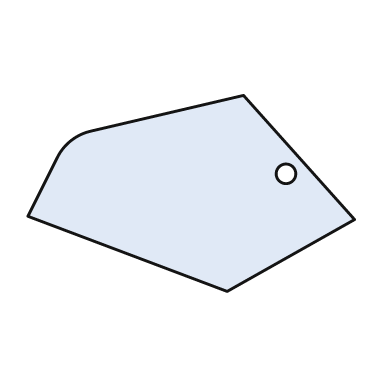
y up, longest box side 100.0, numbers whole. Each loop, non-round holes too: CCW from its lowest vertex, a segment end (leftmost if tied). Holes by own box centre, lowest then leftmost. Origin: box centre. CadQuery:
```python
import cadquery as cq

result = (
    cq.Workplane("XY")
    .moveTo(11.0, -30.0)
    .lineTo(50.0, -8.0)
    .lineTo(16.0, 30.0)
    .lineTo(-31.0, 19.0)
    .threePointArc((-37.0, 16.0), (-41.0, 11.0))
    .lineTo(-50.0, -7.0)
    .close()
    .moveTo(29.0, 6.0)
    .circle(3.0)
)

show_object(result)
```